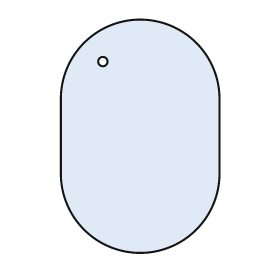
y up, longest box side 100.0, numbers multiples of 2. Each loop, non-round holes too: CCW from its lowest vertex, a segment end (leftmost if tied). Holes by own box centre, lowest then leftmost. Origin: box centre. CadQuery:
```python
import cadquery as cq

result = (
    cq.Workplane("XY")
    .moveTo(-34.0, -16.0)
    .threePointArc((0.0, -50.0), (34.0, -16.0))
    .lineTo(34.0, 16.0)
    .threePointArc((0.0, 50.0), (-34.0, 16.0))
    .close()
    .moveTo(-16.0, 32.0)
    .circle(2.0)
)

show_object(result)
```